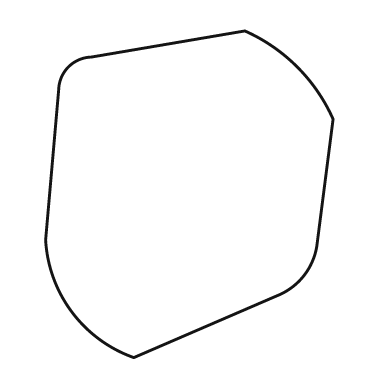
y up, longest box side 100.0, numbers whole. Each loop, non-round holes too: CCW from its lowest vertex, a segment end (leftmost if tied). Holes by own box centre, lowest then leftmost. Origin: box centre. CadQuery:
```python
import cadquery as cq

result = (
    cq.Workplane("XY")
    .moveTo(-17.0, -50.0)
    .lineTo(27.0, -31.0)
    .threePointArc((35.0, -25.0), (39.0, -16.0))
    .lineTo(44.0, 23.0)
    .threePointArc((33.0, 39.0), (17.0, 50.0))
    .lineTo(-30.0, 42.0)
    .threePointArc((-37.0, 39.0), (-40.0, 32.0))
    .lineTo(-44.0, -14.0)
    .threePointArc((-36.0, -36.0), (-17.0, -50.0))
    .close()
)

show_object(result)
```